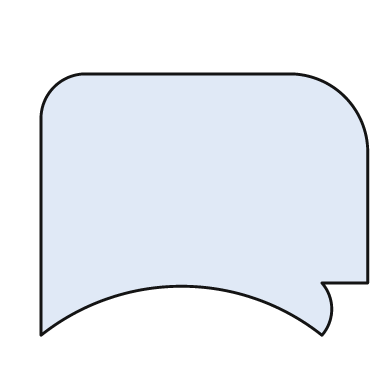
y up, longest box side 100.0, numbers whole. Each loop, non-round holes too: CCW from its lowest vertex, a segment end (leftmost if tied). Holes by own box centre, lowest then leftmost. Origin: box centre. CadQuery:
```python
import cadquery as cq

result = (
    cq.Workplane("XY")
    .moveTo(-50.0, -40.0)
    .threePointArc((-7.0, -25.0), (36.0, -40.0))
    .threePointArc((39.0, -32.0), (36.0, -24.0))
    .lineTo(50.0, -24.0)
    .lineTo(50.0, 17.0)
    .threePointArc((43.0, 33.0), (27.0, 40.0))
    .lineTo(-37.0, 40.0)
    .threePointArc((-46.0, 36.0), (-50.0, 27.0))
    .close()
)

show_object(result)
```